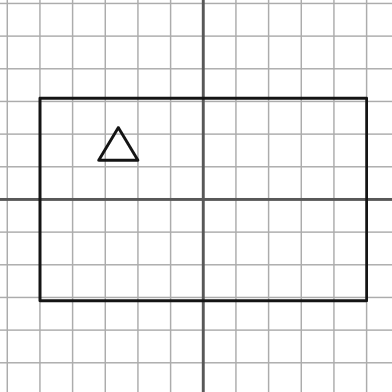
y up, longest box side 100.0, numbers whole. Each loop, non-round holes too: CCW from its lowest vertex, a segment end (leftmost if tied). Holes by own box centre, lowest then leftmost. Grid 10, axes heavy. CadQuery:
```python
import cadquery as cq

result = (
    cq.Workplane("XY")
    .moveTo(-50.0, -31.0)
    .lineTo(50.0, -31.0)
    .lineTo(50.0, 31.0)
    .lineTo(-50.0, 31.0)
    .close()
    .moveTo(-32.0, 12.0)
    .lineTo(-20.0, 12.0)
    .lineTo(-26.0, 22.0)
    .close()
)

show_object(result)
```